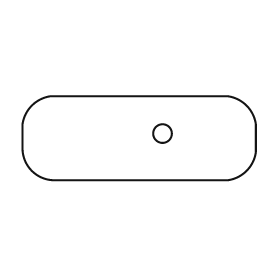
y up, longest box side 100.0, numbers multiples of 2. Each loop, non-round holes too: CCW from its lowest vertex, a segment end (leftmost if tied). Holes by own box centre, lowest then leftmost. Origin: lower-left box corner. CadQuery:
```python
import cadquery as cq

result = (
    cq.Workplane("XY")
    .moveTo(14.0, 0.0)
    .lineTo(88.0, 0.0)
    .threePointArc((96.0, 4.0), (100.0, 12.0))
    .lineTo(100.0, 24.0)
    .threePointArc((96.0, 32.0), (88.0, 36.0))
    .lineTo(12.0, 36.0)
    .threePointArc((4.0, 32.0), (0.0, 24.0))
    .lineTo(0.0, 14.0)
    .threePointArc((4.0, 4.0), (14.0, 0.0))
    .close()
    .moveTo(60.0, 20.0)
    .circle(4.0)
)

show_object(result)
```